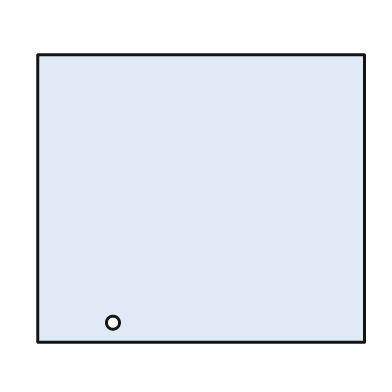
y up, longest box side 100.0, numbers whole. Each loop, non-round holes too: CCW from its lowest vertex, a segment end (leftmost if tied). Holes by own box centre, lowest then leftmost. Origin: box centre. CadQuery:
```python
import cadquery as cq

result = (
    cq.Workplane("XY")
    .moveTo(-50.0, -44.0)
    .lineTo(50.0, -44.0)
    .lineTo(50.0, 44.0)
    .lineTo(-50.0, 44.0)
    .close()
    .moveTo(-27.0, -38.0)
    .circle(2.0)
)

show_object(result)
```